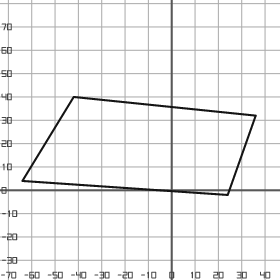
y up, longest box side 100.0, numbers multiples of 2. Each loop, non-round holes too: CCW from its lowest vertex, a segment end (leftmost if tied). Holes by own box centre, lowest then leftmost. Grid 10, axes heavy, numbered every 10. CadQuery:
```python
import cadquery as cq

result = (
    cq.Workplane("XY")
    .moveTo(24.0, -2.0)
    .lineTo(36.0, 32.0)
    .lineTo(-42.0, 40.0)
    .lineTo(-64.0, 4.0)
    .close()
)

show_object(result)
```